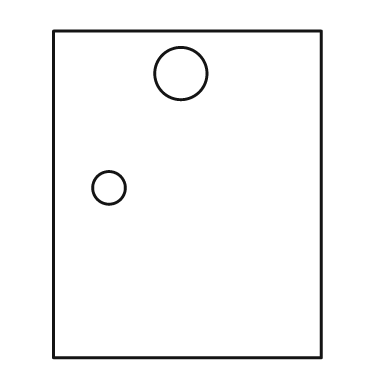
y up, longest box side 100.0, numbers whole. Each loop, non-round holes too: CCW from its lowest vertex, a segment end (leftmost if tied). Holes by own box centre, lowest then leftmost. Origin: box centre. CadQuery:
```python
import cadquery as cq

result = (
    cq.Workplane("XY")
    .moveTo(-41.0, -50.0)
    .lineTo(41.0, -50.0)
    .lineTo(41.0, 50.0)
    .lineTo(-41.0, 50.0)
    .close()
    .moveTo(-24.0, 2.0)
    .circle(5.0)
    .moveTo(-2.0, 37.0)
    .circle(8.0)
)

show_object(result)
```